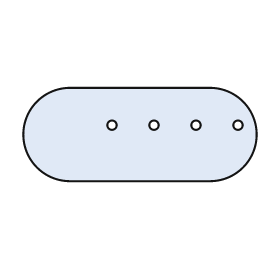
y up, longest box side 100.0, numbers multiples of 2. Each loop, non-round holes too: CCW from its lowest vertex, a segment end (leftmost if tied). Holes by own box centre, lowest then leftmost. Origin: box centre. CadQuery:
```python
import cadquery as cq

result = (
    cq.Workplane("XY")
    .moveTo(-30.0, -20.0)
    .lineTo(30.0, -20.0)
    .threePointArc((50.0, 0.0), (30.0, 20.0))
    .lineTo(-30.0, 20.0)
    .threePointArc((-50.0, 0.0), (-30.0, -20.0))
    .close()
    .moveTo(-12.0, 4.0)
    .circle(2.0)
    .moveTo(6.0, 4.0)
    .circle(2.0)
    .moveTo(24.0, 4.0)
    .circle(2.0)
    .moveTo(42.0, 4.0)
    .circle(2.0)
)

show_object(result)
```